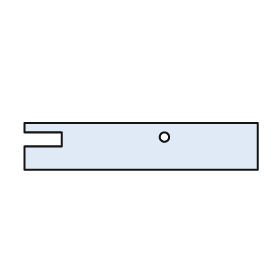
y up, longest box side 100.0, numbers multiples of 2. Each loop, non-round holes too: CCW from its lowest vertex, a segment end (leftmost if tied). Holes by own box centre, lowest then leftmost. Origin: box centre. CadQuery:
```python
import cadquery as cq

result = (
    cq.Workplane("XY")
    .moveTo(-50.0, -10.0)
    .lineTo(50.0, -10.0)
    .lineTo(50.0, 10.0)
    .lineTo(-50.0, 10.0)
    .lineTo(-50.0, 6.0)
    .lineTo(-34.0, 6.0)
    .lineTo(-34.0, 0.0)
    .lineTo(-50.0, 0.0)
    .close()
    .moveTo(10.0, 4.0)
    .circle(2.0)
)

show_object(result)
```